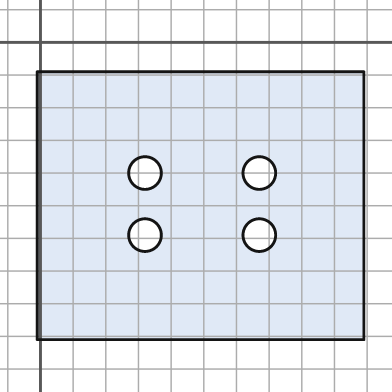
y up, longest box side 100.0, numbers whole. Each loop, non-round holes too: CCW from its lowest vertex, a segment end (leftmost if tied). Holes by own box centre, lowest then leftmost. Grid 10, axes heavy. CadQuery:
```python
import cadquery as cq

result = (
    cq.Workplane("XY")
    .moveTo(-1.0, -91.0)
    .lineTo(99.0, -91.0)
    .lineTo(99.0, -9.0)
    .lineTo(-1.0, -9.0)
    .close()
    .moveTo(32.0, -59.0)
    .circle(5.0)
    .moveTo(67.0, -59.0)
    .circle(5.0)
    .moveTo(32.0, -40.0)
    .circle(5.0)
    .moveTo(67.0, -40.0)
    .circle(5.0)
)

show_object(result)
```